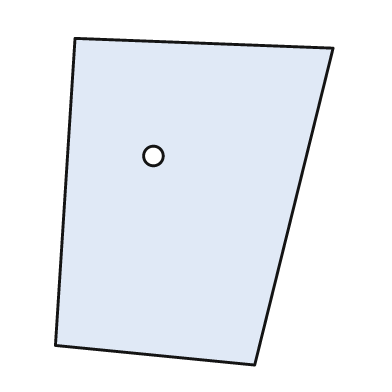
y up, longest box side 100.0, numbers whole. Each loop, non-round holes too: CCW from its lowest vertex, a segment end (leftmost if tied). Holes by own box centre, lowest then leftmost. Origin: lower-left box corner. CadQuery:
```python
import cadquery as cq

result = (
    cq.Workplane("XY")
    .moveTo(61.0, 0.0)
    .lineTo(85.0, 97.0)
    .lineTo(6.0, 100.0)
    .lineTo(0.0, 6.0)
    .close()
    .moveTo(30.0, 64.0)
    .circle(3.0)
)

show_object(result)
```